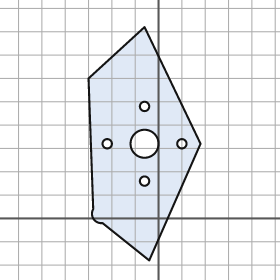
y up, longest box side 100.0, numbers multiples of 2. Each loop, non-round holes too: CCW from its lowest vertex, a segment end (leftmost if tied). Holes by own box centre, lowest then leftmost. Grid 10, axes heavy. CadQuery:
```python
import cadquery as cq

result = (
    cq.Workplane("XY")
    .moveTo(-4.0, -18.0)
    .lineTo(18.0, 32.0)
    .lineTo(-6.0, 82.0)
    .lineTo(-30.0, 60.0)
    .lineTo(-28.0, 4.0)
    .threePointArc((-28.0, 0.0), (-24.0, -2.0))
    .close()
    .moveTo(-6.0, 16.0)
    .circle(2.0)
    .moveTo(-22.0, 32.0)
    .circle(2.0)
    .moveTo(-6.0, 32.0)
    .circle(6.0)
    .moveTo(10.0, 32.0)
    .circle(2.0)
    .moveTo(-6.0, 48.0)
    .circle(2.0)
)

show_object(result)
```